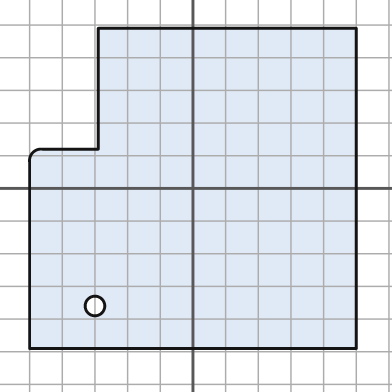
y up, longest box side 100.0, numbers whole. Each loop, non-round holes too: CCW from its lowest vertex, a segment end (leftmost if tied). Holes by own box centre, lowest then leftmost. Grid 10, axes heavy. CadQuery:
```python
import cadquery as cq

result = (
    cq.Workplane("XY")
    .moveTo(-50.0, -49.0)
    .lineTo(50.0, -49.0)
    .lineTo(50.0, 49.0)
    .lineTo(-29.0, 49.0)
    .lineTo(-29.0, 12.0)
    .lineTo(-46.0, 12.0)
    .threePointArc((-49.0, 11.0), (-50.0, 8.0))
    .close()
    .moveTo(-30.0, -36.0)
    .circle(3.0)
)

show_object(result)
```